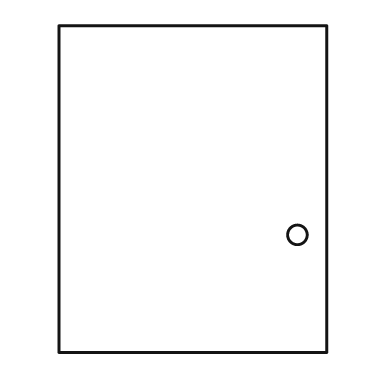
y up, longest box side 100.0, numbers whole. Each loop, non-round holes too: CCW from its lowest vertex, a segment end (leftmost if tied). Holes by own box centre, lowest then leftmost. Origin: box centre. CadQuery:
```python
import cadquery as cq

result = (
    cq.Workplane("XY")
    .moveTo(-41.0, -50.0)
    .lineTo(41.0, -50.0)
    .lineTo(41.0, 50.0)
    .lineTo(-41.0, 50.0)
    .close()
    .moveTo(32.0, -14.0)
    .circle(3.0)
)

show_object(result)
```